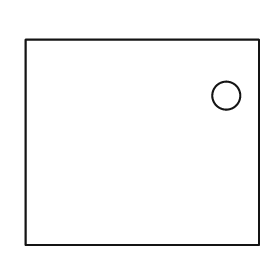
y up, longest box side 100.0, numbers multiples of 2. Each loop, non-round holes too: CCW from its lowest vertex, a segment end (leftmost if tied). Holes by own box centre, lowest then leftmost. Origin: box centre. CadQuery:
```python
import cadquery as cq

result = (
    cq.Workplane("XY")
    .moveTo(-50.0, -44.0)
    .lineTo(50.0, -44.0)
    .lineTo(50.0, 44.0)
    .lineTo(-50.0, 44.0)
    .close()
    .moveTo(36.0, 20.0)
    .circle(6.0)
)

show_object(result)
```